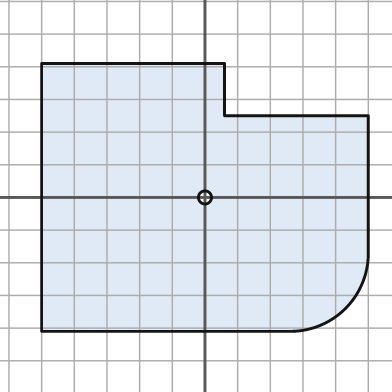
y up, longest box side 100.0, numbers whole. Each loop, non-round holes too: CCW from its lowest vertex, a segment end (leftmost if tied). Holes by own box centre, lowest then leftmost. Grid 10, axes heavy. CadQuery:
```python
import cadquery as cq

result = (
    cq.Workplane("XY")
    .moveTo(-50.0, -41.0)
    .lineTo(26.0, -41.0)
    .threePointArc((43.0, -34.0), (50.0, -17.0))
    .lineTo(50.0, 25.0)
    .lineTo(6.0, 25.0)
    .lineTo(6.0, 41.0)
    .lineTo(-50.0, 41.0)
    .close()
    .moveTo(0.0, 0.0)
    .circle(2.0)
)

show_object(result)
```